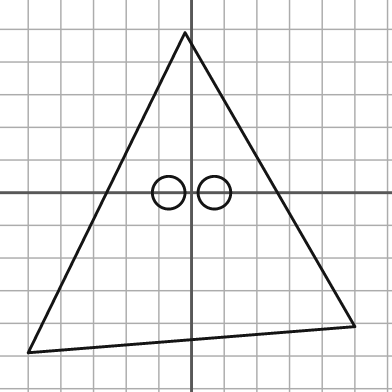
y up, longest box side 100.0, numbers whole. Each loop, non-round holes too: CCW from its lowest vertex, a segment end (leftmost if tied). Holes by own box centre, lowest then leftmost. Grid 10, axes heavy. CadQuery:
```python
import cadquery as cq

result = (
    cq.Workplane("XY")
    .moveTo(-50.0, -49.0)
    .lineTo(50.0, -41.0)
    .lineTo(-2.0, 49.0)
    .close()
    .moveTo(-7.0, 0.0)
    .circle(5.0)
    .moveTo(7.0, 0.0)
    .circle(5.0)
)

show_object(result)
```